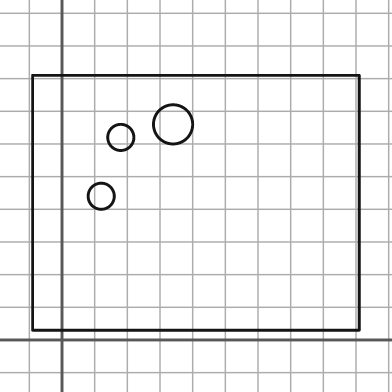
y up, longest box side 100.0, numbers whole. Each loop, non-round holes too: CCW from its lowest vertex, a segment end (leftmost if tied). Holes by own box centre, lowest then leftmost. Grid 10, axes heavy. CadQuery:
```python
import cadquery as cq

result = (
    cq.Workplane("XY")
    .moveTo(-9.0, 3.0)
    .lineTo(91.0, 3.0)
    .lineTo(91.0, 81.0)
    .lineTo(-9.0, 81.0)
    .close()
    .moveTo(12.0, 44.0)
    .circle(4.0)
    .moveTo(18.0, 62.0)
    .circle(4.0)
    .moveTo(34.0, 66.0)
    .circle(6.0)
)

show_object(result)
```